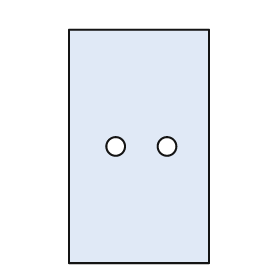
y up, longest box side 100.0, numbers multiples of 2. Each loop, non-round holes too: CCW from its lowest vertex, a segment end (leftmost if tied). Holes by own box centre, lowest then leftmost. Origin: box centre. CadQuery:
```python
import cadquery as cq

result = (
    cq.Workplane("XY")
    .moveTo(-30.0, -50.0)
    .lineTo(30.0, -50.0)
    .lineTo(30.0, 50.0)
    .lineTo(-30.0, 50.0)
    .close()
    .moveTo(-10.0, 0.0)
    .circle(4.0)
    .moveTo(12.0, 0.0)
    .circle(4.0)
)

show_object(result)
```